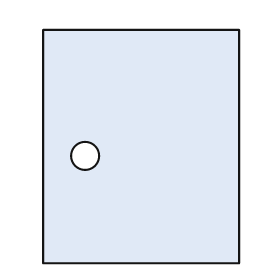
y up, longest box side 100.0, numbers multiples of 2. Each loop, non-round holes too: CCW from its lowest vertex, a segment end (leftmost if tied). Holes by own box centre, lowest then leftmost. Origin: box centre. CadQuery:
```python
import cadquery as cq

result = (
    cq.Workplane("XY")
    .moveTo(-42.0, -50.0)
    .lineTo(42.0, -50.0)
    .lineTo(42.0, 50.0)
    .lineTo(-42.0, 50.0)
    .close()
    .moveTo(-24.0, -4.0)
    .circle(6.0)
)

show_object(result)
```